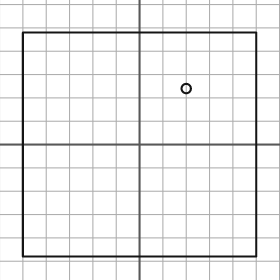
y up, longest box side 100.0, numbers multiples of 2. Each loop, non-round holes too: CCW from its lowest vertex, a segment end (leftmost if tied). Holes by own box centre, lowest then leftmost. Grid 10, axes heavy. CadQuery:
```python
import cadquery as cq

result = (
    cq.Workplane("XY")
    .moveTo(-50.0, -48.0)
    .lineTo(50.0, -48.0)
    .lineTo(50.0, 48.0)
    .lineTo(-50.0, 48.0)
    .close()
    .moveTo(20.0, 24.0)
    .circle(2.0)
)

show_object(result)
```